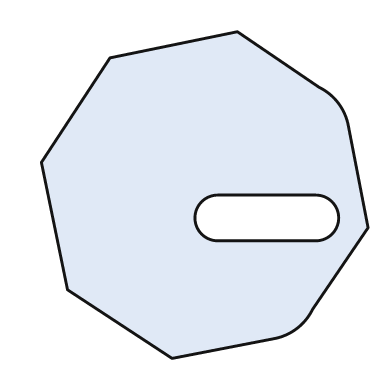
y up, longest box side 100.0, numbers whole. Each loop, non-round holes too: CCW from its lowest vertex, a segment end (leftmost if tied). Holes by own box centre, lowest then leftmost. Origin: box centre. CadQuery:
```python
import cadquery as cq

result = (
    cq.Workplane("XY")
    .moveTo(-10.0, -50.0)
    .lineTo(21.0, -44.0)
    .threePointArc((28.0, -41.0), (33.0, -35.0))
    .lineTo(50.0, -10.0)
    .lineTo(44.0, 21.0)
    .threePointArc((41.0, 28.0), (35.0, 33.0))
    .lineTo(10.0, 50.0)
    .lineTo(-29.0, 42.0)
    .lineTo(-50.0, 10.0)
    .lineTo(-42.0, -29.0)
    .close()
    .moveTo(4.0, -14.0)
    .lineTo(34.0, -14.0)
    .threePointArc((41.0, -7.0), (34.0, 0.0))
    .lineTo(4.0, 0.0)
    .threePointArc((-3.0, -7.0), (4.0, -14.0))
    .close()
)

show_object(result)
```